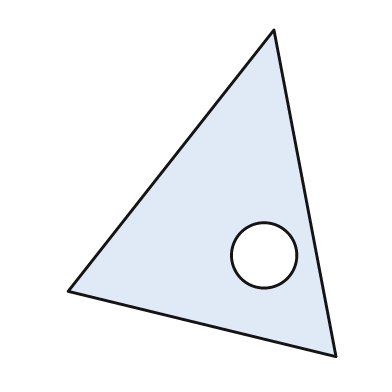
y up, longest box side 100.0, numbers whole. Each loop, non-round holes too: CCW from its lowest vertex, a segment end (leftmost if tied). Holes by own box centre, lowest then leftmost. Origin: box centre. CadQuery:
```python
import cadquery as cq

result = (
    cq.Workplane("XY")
    .moveTo(41.0, -50.0)
    .lineTo(22.0, 50.0)
    .lineTo(-41.0, -30.0)
    .close()
    .moveTo(19.0, -19.0)
    .circle(10.0)
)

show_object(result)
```